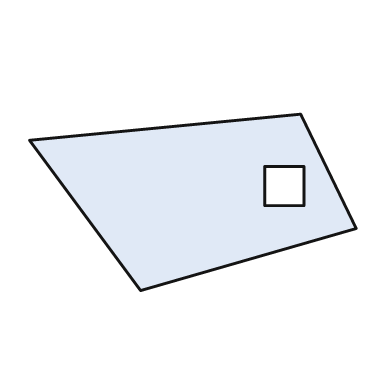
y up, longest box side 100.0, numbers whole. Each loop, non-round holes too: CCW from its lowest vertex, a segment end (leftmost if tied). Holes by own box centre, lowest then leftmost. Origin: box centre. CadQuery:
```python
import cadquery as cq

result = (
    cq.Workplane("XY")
    .moveTo(-16.0, -27.0)
    .lineTo(50.0, -8.0)
    .lineTo(33.0, 27.0)
    .lineTo(-50.0, 19.0)
    .close()
    .moveTo(22.0, -1.0)
    .lineTo(34.0, -1.0)
    .lineTo(34.0, 11.0)
    .lineTo(22.0, 11.0)
    .close()
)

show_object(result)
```